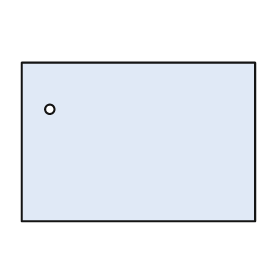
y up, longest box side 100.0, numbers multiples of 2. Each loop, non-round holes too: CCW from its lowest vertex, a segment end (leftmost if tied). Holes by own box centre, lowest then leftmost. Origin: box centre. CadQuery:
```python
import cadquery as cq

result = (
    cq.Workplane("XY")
    .moveTo(-50.0, -34.0)
    .lineTo(50.0, -34.0)
    .lineTo(50.0, 34.0)
    .lineTo(-50.0, 34.0)
    .close()
    .moveTo(-38.0, 14.0)
    .circle(2.0)
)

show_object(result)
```